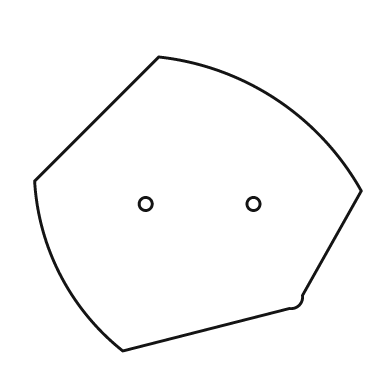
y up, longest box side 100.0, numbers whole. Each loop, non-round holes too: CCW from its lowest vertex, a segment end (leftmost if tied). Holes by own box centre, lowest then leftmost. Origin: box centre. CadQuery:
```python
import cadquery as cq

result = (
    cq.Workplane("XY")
    .moveTo(-23.0, -45.0)
    .lineTo(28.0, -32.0)
    .threePointArc((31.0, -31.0), (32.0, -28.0))
    .lineTo(50.0, 4.0)
    .threePointArc((24.0, 32.0), (-12.0, 45.0))
    .lineTo(-50.0, 7.0)
    .threePointArc((-42.0, -22.0), (-23.0, -45.0))
    .close()
    .moveTo(-16.0, 0.0)
    .circle(2.0)
    .moveTo(17.0, 0.0)
    .circle(2.0)
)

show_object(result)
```